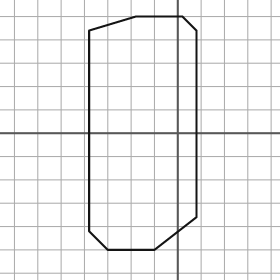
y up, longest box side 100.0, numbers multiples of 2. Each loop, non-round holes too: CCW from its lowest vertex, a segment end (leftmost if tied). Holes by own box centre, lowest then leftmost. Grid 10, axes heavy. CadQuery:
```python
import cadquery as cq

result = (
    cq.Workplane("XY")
    .moveTo(-30.0, -50.0)
    .lineTo(-10.0, -50.0)
    .lineTo(8.0, -36.0)
    .lineTo(8.0, 44.0)
    .lineTo(2.0, 50.0)
    .lineTo(-18.0, 50.0)
    .lineTo(-38.0, 44.0)
    .lineTo(-38.0, -42.0)
    .close()
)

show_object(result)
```